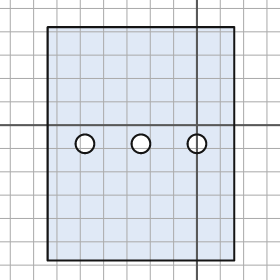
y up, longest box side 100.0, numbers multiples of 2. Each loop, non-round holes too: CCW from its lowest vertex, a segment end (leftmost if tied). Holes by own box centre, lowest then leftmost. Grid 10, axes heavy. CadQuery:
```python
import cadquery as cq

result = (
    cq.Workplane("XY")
    .moveTo(-64.0, -58.0)
    .lineTo(16.0, -58.0)
    .lineTo(16.0, 42.0)
    .lineTo(-64.0, 42.0)
    .close()
    .moveTo(-48.0, -8.0)
    .circle(4.0)
    .moveTo(-24.0, -8.0)
    .circle(4.0)
    .moveTo(0.0, -8.0)
    .circle(4.0)
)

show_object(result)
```